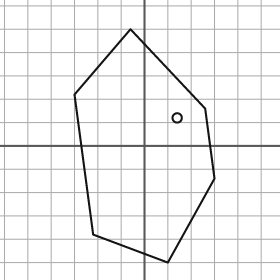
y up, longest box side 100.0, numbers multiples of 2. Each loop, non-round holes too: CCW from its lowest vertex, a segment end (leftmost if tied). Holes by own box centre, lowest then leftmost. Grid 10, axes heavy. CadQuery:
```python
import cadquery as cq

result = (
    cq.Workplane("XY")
    .moveTo(10.0, -50.0)
    .lineTo(30.0, -14.0)
    .lineTo(26.0, 16.0)
    .lineTo(-6.0, 50.0)
    .lineTo(-30.0, 22.0)
    .lineTo(-22.0, -38.0)
    .close()
    .moveTo(14.0, 12.0)
    .circle(2.0)
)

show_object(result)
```